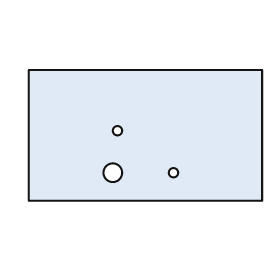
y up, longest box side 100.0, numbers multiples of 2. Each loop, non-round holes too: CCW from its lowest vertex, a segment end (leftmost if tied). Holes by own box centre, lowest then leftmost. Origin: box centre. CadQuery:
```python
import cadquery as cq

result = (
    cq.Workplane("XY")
    .moveTo(-50.0, -28.0)
    .lineTo(50.0, -28.0)
    .lineTo(50.0, 28.0)
    .lineTo(-50.0, 28.0)
    .close()
    .moveTo(-14.0, -16.0)
    .circle(4.0)
    .moveTo(12.0, -16.0)
    .circle(2.0)
    .moveTo(-12.0, 2.0)
    .circle(2.0)
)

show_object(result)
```